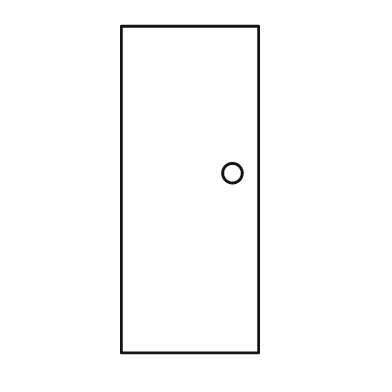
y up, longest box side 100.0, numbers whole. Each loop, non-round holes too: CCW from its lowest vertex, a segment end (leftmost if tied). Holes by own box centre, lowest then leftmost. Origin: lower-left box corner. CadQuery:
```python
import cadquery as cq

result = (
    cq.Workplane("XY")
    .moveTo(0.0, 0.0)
    .lineTo(42.0, 0.0)
    .lineTo(42.0, 100.0)
    .lineTo(0.0, 100.0)
    .close()
    .moveTo(34.0, 55.0)
    .circle(3.0)
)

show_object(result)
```